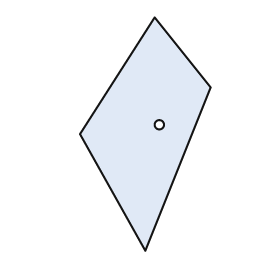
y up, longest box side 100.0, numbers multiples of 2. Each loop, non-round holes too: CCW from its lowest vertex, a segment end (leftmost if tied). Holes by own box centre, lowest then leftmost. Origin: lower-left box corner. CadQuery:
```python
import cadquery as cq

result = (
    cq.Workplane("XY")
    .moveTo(28.0, 0.0)
    .lineTo(56.0, 70.0)
    .lineTo(32.0, 100.0)
    .lineTo(0.0, 50.0)
    .close()
    .moveTo(34.0, 54.0)
    .circle(2.0)
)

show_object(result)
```